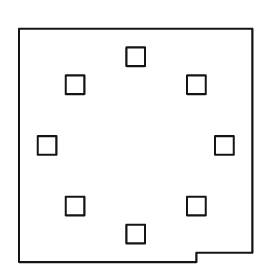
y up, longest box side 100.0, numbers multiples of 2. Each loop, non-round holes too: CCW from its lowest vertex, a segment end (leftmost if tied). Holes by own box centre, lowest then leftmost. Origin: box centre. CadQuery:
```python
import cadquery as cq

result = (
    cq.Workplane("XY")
    .moveTo(-50.0, -50.0)
    .lineTo(26.0, -50.0)
    .lineTo(26.0, -46.0)
    .lineTo(50.0, -46.0)
    .lineTo(50.0, 50.0)
    .lineTo(-50.0, 50.0)
    .close()
    .moveTo(-4.0, -42.0)
    .lineTo(4.0, -42.0)
    .lineTo(4.0, -34.0)
    .lineTo(-4.0, -34.0)
    .close()
    .moveTo(-30.0, -30.0)
    .lineTo(-22.0, -30.0)
    .lineTo(-22.0, -22.0)
    .lineTo(-30.0, -22.0)
    .close()
    .moveTo(22.0, -30.0)
    .lineTo(30.0, -30.0)
    .lineTo(30.0, -22.0)
    .lineTo(22.0, -22.0)
    .close()
    .moveTo(-42.0, -4.0)
    .lineTo(-34.0, -4.0)
    .lineTo(-34.0, 4.0)
    .lineTo(-42.0, 4.0)
    .close()
    .moveTo(34.0, -4.0)
    .lineTo(42.0, -4.0)
    .lineTo(42.0, 4.0)
    .lineTo(34.0, 4.0)
    .close()
    .moveTo(-30.0, 22.0)
    .lineTo(-22.0, 22.0)
    .lineTo(-22.0, 30.0)
    .lineTo(-30.0, 30.0)
    .close()
    .moveTo(22.0, 22.0)
    .lineTo(30.0, 22.0)
    .lineTo(30.0, 30.0)
    .lineTo(22.0, 30.0)
    .close()
    .moveTo(-4.0, 34.0)
    .lineTo(4.0, 34.0)
    .lineTo(4.0, 42.0)
    .lineTo(-4.0, 42.0)
    .close()
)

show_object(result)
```